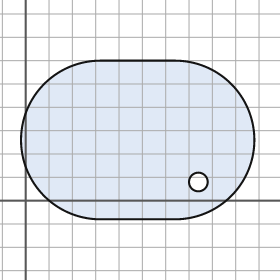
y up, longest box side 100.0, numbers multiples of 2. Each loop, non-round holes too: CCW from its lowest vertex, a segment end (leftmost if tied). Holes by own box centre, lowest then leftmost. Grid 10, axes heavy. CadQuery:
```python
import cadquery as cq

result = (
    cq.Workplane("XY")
    .moveTo(32.0, -8.0)
    .lineTo(64.0, -8.0)
    .threePointArc((98.0, 26.0), (64.0, 60.0))
    .lineTo(32.0, 60.0)
    .threePointArc((-2.0, 26.0), (32.0, -8.0))
    .close()
    .moveTo(74.0, 8.0)
    .circle(4.0)
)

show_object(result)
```